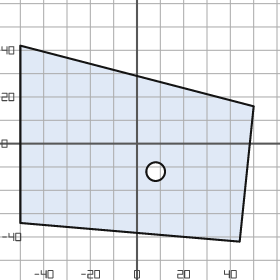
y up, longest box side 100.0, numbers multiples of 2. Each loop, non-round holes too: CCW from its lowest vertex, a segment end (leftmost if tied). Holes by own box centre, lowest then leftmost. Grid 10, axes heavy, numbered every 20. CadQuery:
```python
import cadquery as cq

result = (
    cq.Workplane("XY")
    .moveTo(44.0, -42.0)
    .lineTo(50.0, 16.0)
    .lineTo(-50.0, 42.0)
    .lineTo(-50.0, -34.0)
    .close()
    .moveTo(8.0, -12.0)
    .circle(4.0)
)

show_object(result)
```